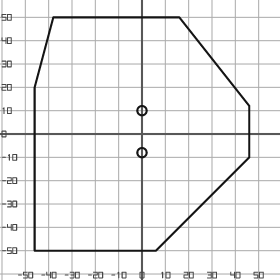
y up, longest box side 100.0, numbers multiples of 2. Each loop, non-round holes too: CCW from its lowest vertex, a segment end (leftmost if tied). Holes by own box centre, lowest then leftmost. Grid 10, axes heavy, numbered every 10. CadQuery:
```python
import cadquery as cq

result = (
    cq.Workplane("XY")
    .moveTo(-46.0, -50.0)
    .lineTo(6.0, -50.0)
    .lineTo(46.0, -10.0)
    .lineTo(46.0, 12.0)
    .lineTo(16.0, 50.0)
    .lineTo(-38.0, 50.0)
    .lineTo(-46.0, 20.0)
    .close()
    .moveTo(0.0, -8.0)
    .circle(2.0)
    .moveTo(0.0, 10.0)
    .circle(2.0)
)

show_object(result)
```